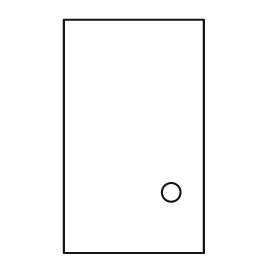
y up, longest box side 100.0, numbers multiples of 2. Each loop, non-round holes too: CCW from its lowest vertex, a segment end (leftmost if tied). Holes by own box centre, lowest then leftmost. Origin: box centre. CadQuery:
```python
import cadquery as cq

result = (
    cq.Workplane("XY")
    .moveTo(-30.0, -50.0)
    .lineTo(30.0, -50.0)
    .lineTo(30.0, 50.0)
    .lineTo(-30.0, 50.0)
    .close()
    .moveTo(16.0, -24.0)
    .circle(4.0)
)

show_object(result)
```